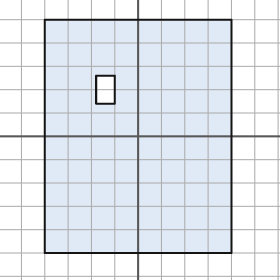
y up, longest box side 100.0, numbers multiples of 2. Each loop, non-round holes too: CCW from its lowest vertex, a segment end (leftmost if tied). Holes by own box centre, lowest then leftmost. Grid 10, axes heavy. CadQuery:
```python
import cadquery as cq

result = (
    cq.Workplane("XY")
    .moveTo(-40.0, -50.0)
    .lineTo(40.0, -50.0)
    .lineTo(40.0, 50.0)
    .lineTo(-40.0, 50.0)
    .close()
    .moveTo(-18.0, 14.0)
    .lineTo(-10.0, 14.0)
    .lineTo(-10.0, 26.0)
    .lineTo(-18.0, 26.0)
    .close()
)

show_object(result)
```